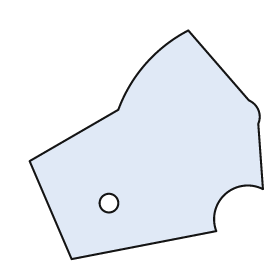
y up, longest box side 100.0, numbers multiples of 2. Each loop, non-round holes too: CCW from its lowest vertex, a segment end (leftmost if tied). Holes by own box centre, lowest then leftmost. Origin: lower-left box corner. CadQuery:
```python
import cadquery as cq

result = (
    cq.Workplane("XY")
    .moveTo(18.0, 0.0)
    .lineTo(80.0, 12.0)
    .threePointArc((84.0, 28.0), (100.0, 30.0))
    .lineTo(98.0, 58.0)
    .threePointArc((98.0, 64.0), (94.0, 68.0))
    .lineTo(68.0, 98.0)
    .threePointArc((50.0, 84.0), (38.0, 64.0))
    .lineTo(0.0, 42.0)
    .close()
    .moveTo(34.0, 24.0)
    .circle(4.0)
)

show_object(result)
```